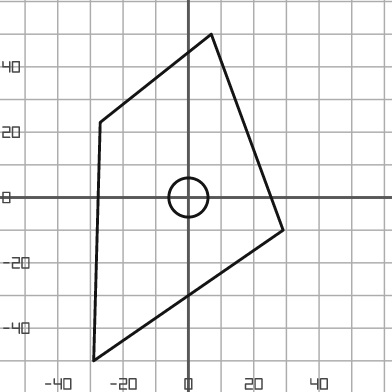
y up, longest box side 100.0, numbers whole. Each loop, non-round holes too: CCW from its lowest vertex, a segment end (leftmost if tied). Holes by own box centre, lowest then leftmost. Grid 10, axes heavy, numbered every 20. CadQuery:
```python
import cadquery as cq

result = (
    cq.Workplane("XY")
    .moveTo(-29.0, -50.0)
    .lineTo(29.0, -10.0)
    .lineTo(7.0, 50.0)
    .lineTo(-27.0, 23.0)
    .close()
    .moveTo(0.0, 0.0)
    .circle(6.0)
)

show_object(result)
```